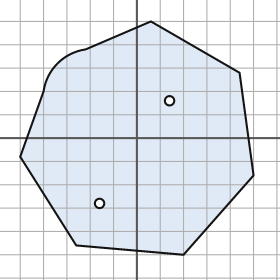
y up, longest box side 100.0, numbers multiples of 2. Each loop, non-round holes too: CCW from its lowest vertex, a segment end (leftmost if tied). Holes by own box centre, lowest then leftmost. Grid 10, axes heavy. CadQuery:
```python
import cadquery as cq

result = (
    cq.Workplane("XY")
    .moveTo(20.0, -50.0)
    .lineTo(50.0, -16.0)
    .lineTo(44.0, 28.0)
    .lineTo(6.0, 50.0)
    .lineTo(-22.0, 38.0)
    .threePointArc((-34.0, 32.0), (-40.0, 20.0))
    .lineTo(-50.0, -8.0)
    .lineTo(-26.0, -46.0)
    .close()
    .moveTo(-16.0, -28.0)
    .circle(2.0)
    .moveTo(14.0, 16.0)
    .circle(2.0)
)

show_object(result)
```